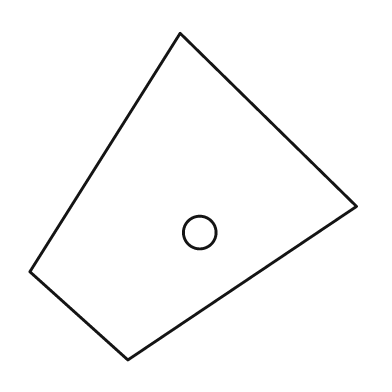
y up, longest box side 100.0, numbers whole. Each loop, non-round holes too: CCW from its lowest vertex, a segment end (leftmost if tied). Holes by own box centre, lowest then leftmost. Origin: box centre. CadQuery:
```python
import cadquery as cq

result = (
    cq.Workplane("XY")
    .moveTo(-20.0, -50.0)
    .lineTo(50.0, -3.0)
    .lineTo(-4.0, 50.0)
    .lineTo(-50.0, -23.0)
    .close()
    .moveTo(2.0, -11.0)
    .circle(5.0)
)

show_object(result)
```